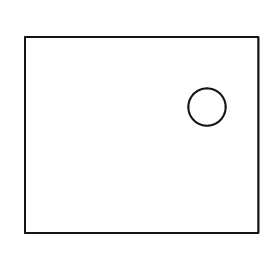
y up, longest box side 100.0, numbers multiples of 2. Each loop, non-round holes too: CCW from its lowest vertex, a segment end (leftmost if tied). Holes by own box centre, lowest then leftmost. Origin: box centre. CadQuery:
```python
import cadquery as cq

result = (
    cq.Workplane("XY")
    .moveTo(-50.0, -42.0)
    .lineTo(50.0, -42.0)
    .lineTo(50.0, 42.0)
    .lineTo(-50.0, 42.0)
    .close()
    .moveTo(28.0, 12.0)
    .circle(8.0)
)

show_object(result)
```